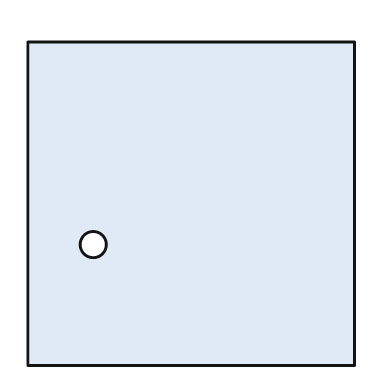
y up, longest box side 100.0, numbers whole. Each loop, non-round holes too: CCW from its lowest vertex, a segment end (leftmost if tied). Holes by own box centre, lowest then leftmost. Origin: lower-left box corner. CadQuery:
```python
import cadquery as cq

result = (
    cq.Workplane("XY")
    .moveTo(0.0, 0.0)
    .lineTo(100.0, 0.0)
    .lineTo(100.0, 99.0)
    .lineTo(0.0, 99.0)
    .close()
    .moveTo(20.0, 37.0)
    .circle(4.0)
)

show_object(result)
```